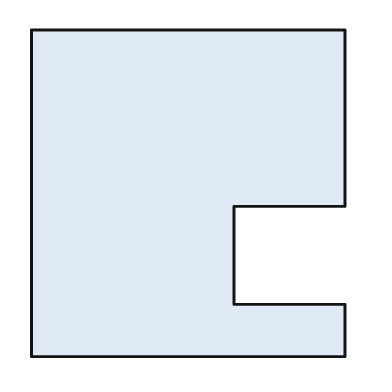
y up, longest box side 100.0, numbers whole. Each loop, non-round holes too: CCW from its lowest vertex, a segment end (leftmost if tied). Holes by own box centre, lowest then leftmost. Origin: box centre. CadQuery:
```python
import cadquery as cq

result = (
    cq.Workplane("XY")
    .moveTo(-48.0, -50.0)
    .lineTo(48.0, -50.0)
    .lineTo(48.0, -34.0)
    .lineTo(14.0, -34.0)
    .lineTo(14.0, -4.0)
    .lineTo(48.0, -4.0)
    .lineTo(48.0, 50.0)
    .lineTo(-48.0, 50.0)
    .close()
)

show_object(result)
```